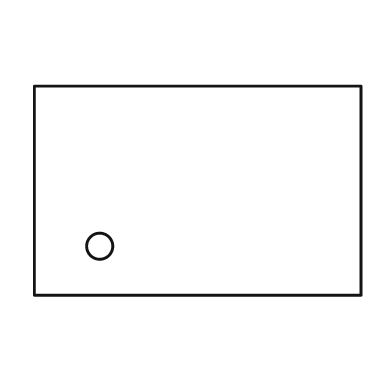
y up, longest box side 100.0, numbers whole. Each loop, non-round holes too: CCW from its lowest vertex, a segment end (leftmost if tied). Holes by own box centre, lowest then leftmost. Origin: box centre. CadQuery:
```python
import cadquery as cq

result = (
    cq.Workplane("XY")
    .moveTo(-50.0, -32.0)
    .lineTo(50.0, -32.0)
    .lineTo(50.0, 32.0)
    .lineTo(-50.0, 32.0)
    .close()
    .moveTo(-30.0, -17.0)
    .circle(4.0)
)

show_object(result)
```